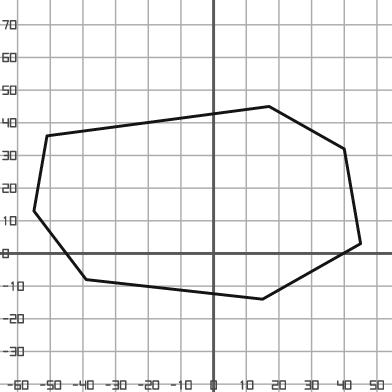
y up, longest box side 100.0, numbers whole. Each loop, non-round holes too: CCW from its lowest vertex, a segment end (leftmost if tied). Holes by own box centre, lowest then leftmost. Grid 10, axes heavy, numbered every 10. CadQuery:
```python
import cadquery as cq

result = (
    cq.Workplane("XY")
    .moveTo(15.0, -14.0)
    .lineTo(45.0, 3.0)
    .lineTo(40.0, 32.0)
    .lineTo(17.0, 45.0)
    .lineTo(-51.0, 36.0)
    .lineTo(-55.0, 13.0)
    .lineTo(-39.0, -8.0)
    .close()
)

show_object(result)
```